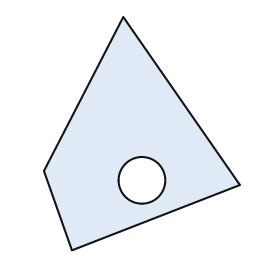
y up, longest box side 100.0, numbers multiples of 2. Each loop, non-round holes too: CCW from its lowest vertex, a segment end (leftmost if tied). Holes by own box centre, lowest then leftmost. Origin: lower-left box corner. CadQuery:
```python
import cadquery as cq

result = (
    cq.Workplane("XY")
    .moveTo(12.0, 0.0)
    .lineTo(84.0, 28.0)
    .lineTo(34.0, 100.0)
    .lineTo(0.0, 34.0)
    .close()
    .moveTo(42.0, 30.0)
    .circle(10.0)
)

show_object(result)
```